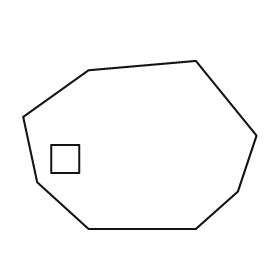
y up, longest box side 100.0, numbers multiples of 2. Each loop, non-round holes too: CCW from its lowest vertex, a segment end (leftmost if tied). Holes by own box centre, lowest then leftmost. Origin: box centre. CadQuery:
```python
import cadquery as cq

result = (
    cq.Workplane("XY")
    .moveTo(-22.0, -36.0)
    .lineTo(24.0, -36.0)
    .lineTo(42.0, -20.0)
    .lineTo(50.0, 4.0)
    .lineTo(24.0, 36.0)
    .lineTo(-22.0, 32.0)
    .lineTo(-50.0, 12.0)
    .lineTo(-44.0, -16.0)
    .close()
    .moveTo(-38.0, -12.0)
    .lineTo(-26.0, -12.0)
    .lineTo(-26.0, 0.0)
    .lineTo(-38.0, 0.0)
    .close()
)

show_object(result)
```